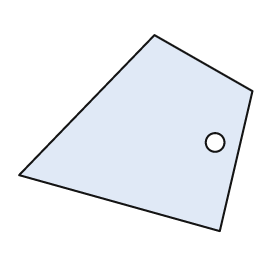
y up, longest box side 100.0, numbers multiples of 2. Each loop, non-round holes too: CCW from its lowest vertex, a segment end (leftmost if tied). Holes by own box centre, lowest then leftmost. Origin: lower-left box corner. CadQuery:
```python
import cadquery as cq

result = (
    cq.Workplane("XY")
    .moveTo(86.0, 0.0)
    .lineTo(100.0, 60.0)
    .lineTo(58.0, 84.0)
    .lineTo(0.0, 24.0)
    .close()
    .moveTo(84.0, 38.0)
    .circle(4.0)
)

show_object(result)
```